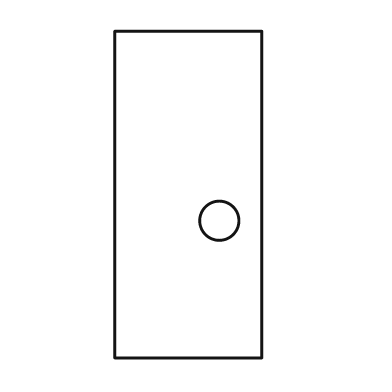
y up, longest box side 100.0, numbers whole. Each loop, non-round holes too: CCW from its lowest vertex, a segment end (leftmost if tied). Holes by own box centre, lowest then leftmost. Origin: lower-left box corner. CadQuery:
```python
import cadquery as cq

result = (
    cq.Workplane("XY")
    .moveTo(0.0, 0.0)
    .lineTo(45.0, 0.0)
    .lineTo(45.0, 100.0)
    .lineTo(0.0, 100.0)
    .close()
    .moveTo(32.0, 42.0)
    .circle(6.0)
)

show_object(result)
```